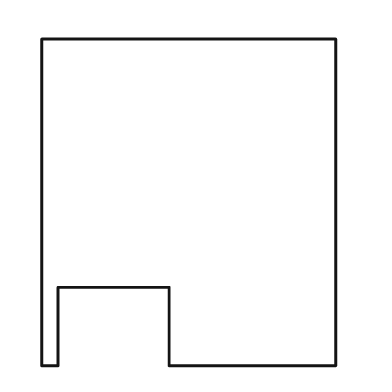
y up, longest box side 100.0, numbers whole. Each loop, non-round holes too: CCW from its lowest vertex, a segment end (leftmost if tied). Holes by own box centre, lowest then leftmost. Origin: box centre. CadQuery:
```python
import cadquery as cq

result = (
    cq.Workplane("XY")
    .moveTo(-45.0, -50.0)
    .lineTo(-40.0, -50.0)
    .lineTo(-40.0, -26.0)
    .lineTo(-6.0, -26.0)
    .lineTo(-6.0, -50.0)
    .lineTo(45.0, -50.0)
    .lineTo(45.0, 50.0)
    .lineTo(-45.0, 50.0)
    .close()
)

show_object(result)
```